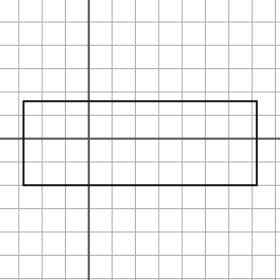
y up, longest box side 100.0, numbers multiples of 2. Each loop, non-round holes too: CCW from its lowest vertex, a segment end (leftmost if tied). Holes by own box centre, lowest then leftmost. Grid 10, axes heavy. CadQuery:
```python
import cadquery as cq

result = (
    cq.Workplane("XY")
    .moveTo(-28.0, -20.0)
    .lineTo(72.0, -20.0)
    .lineTo(72.0, 16.0)
    .lineTo(-28.0, 16.0)
    .close()
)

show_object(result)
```